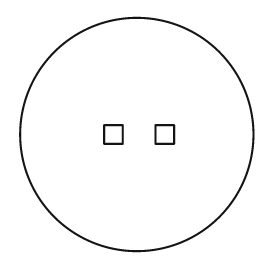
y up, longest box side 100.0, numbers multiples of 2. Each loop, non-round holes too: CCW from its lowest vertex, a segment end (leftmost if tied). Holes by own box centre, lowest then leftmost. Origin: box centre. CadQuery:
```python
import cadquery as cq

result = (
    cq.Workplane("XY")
    .moveTo(0.0, 0.0)
    .circle(50.0)
    .moveTo(-14.0, -4.0)
    .lineTo(-6.0, -4.0)
    .lineTo(-6.0, 4.0)
    .lineTo(-14.0, 4.0)
    .close()
    .moveTo(8.0, -4.0)
    .lineTo(16.0, -4.0)
    .lineTo(16.0, 4.0)
    .lineTo(8.0, 4.0)
    .close()
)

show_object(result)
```